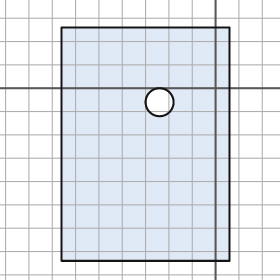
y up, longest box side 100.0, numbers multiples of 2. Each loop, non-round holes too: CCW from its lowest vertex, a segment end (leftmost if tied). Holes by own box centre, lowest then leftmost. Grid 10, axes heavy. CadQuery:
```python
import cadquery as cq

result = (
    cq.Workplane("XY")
    .moveTo(-66.0, -74.0)
    .lineTo(6.0, -74.0)
    .lineTo(6.0, 26.0)
    .lineTo(-66.0, 26.0)
    .close()
    .moveTo(-24.0, -6.0)
    .circle(6.0)
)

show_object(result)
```